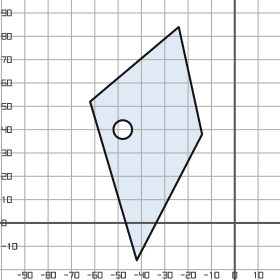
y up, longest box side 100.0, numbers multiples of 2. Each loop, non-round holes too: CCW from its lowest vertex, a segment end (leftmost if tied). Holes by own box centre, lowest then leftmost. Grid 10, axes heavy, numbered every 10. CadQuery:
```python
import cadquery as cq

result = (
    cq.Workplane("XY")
    .moveTo(-42.0, -16.0)
    .lineTo(-14.0, 38.0)
    .lineTo(-24.0, 84.0)
    .lineTo(-62.0, 52.0)
    .close()
    .moveTo(-48.0, 40.0)
    .circle(4.0)
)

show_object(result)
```